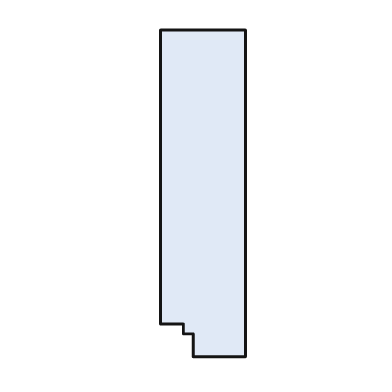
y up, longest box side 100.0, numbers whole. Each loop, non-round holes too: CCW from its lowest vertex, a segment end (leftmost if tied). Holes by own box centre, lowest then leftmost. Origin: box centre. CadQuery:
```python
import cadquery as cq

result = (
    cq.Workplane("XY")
    .moveTo(-3.0, -50.0)
    .lineTo(13.0, -50.0)
    .lineTo(13.0, 50.0)
    .lineTo(-13.0, 50.0)
    .lineTo(-13.0, -40.0)
    .lineTo(-6.0, -40.0)
    .lineTo(-6.0, -43.0)
    .lineTo(-3.0, -43.0)
    .close()
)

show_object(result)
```